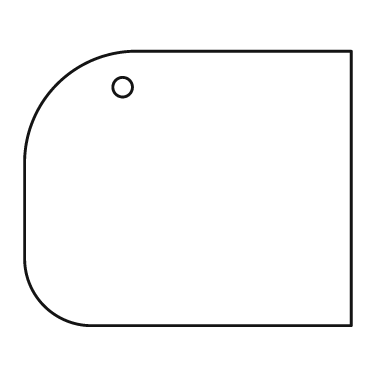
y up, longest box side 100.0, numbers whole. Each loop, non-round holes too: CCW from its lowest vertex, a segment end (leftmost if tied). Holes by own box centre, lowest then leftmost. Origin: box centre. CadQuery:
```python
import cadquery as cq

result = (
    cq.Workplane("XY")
    .moveTo(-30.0, -42.0)
    .lineTo(50.0, -42.0)
    .lineTo(50.0, 42.0)
    .lineTo(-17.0, 42.0)
    .threePointArc((-40.0, 32.0), (-50.0, 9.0))
    .lineTo(-50.0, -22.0)
    .threePointArc((-44.0, -36.0), (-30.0, -42.0))
    .close()
    .moveTo(-20.0, 31.0)
    .circle(3.0)
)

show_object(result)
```